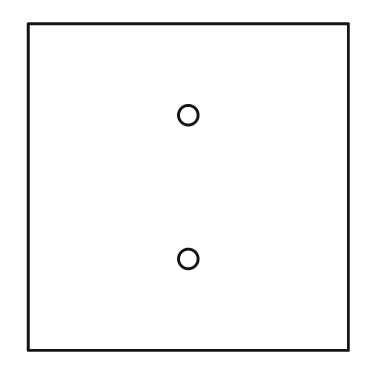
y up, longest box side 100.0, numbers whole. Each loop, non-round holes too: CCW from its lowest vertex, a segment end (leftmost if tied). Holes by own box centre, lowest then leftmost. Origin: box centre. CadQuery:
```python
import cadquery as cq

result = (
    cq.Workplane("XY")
    .moveTo(-49.0, -50.0)
    .lineTo(49.0, -50.0)
    .lineTo(49.0, 50.0)
    .lineTo(-49.0, 50.0)
    .close()
    .moveTo(0.0, -22.0)
    .circle(3.0)
    .moveTo(0.0, 22.0)
    .circle(3.0)
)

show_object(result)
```